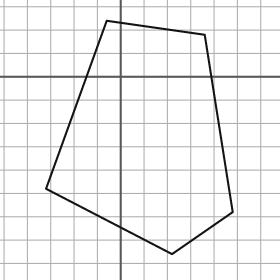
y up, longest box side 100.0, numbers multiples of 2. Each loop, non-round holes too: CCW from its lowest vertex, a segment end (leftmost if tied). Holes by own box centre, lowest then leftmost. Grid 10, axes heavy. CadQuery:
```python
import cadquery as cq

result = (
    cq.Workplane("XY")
    .moveTo(22.0, -76.0)
    .lineTo(48.0, -58.0)
    .lineTo(36.0, 18.0)
    .lineTo(-6.0, 24.0)
    .lineTo(-32.0, -48.0)
    .close()
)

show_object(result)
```